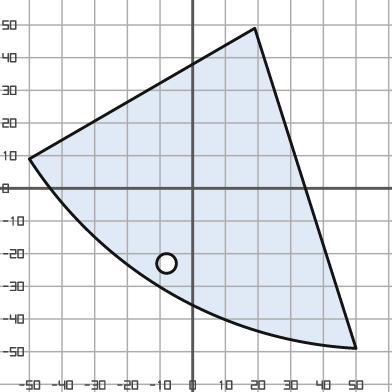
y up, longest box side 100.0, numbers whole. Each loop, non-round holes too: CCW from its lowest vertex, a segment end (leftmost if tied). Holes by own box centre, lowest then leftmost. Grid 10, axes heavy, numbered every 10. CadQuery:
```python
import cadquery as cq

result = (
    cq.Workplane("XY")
    .moveTo(50.0, -49.0)
    .lineTo(19.0, 49.0)
    .lineTo(-50.0, 9.0)
    .threePointArc((-7.0, -32.0), (50.0, -49.0))
    .close()
    .moveTo(-8.0, -23.0)
    .circle(3.0)
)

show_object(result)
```